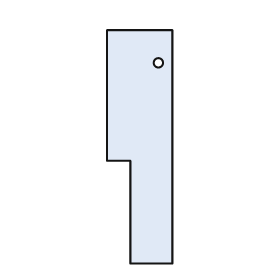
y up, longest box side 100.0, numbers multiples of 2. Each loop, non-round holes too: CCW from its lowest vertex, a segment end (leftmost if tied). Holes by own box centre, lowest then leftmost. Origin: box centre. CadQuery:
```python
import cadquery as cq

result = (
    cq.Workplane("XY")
    .moveTo(-4.0, -50.0)
    .lineTo(14.0, -50.0)
    .lineTo(14.0, 50.0)
    .lineTo(-14.0, 50.0)
    .lineTo(-14.0, -6.0)
    .lineTo(-4.0, -6.0)
    .close()
    .moveTo(8.0, 36.0)
    .circle(2.0)
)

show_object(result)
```